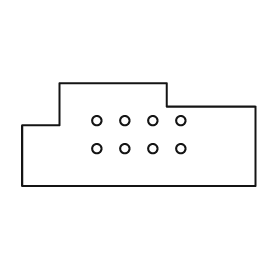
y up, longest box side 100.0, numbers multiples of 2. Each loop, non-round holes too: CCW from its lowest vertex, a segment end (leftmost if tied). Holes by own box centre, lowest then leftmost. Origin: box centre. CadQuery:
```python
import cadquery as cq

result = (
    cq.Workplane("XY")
    .moveTo(-50.0, -22.0)
    .lineTo(50.0, -22.0)
    .lineTo(50.0, 12.0)
    .lineTo(12.0, 12.0)
    .lineTo(12.0, 22.0)
    .lineTo(-34.0, 22.0)
    .lineTo(-34.0, 4.0)
    .lineTo(-50.0, 4.0)
    .close()
    .moveTo(-18.0, -6.0)
    .circle(2.0)
    .moveTo(-6.0, -6.0)
    .circle(2.0)
    .moveTo(6.0, -6.0)
    .circle(2.0)
    .moveTo(18.0, -6.0)
    .circle(2.0)
    .moveTo(-18.0, 6.0)
    .circle(2.0)
    .moveTo(-6.0, 6.0)
    .circle(2.0)
    .moveTo(6.0, 6.0)
    .circle(2.0)
    .moveTo(18.0, 6.0)
    .circle(2.0)
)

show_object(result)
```